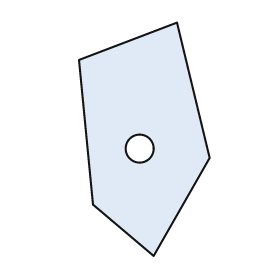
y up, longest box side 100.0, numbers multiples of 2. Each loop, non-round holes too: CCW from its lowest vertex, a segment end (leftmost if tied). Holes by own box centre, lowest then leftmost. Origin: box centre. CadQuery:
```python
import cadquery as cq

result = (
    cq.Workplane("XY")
    .moveTo(4.0, -50.0)
    .lineTo(28.0, -8.0)
    .lineTo(14.0, 50.0)
    .lineTo(-28.0, 34.0)
    .lineTo(-22.0, -28.0)
    .close()
    .moveTo(-2.0, -4.0)
    .circle(6.0)
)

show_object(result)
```